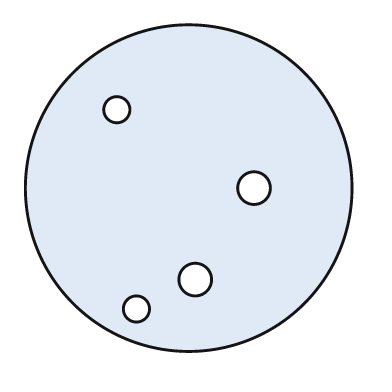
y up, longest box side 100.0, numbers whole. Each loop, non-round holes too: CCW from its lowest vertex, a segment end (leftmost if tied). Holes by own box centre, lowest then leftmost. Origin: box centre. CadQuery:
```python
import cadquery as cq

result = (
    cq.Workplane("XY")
    .moveTo(0.0, 0.0)
    .circle(50.0)
    .moveTo(-16.0, -37.0)
    .circle(4.0)
    .moveTo(2.0, -28.0)
    .circle(5.0)
    .moveTo(20.0, 0.0)
    .circle(5.0)
    .moveTo(-22.0, 24.0)
    .circle(4.0)
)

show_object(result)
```